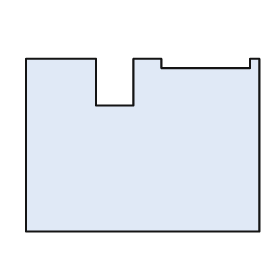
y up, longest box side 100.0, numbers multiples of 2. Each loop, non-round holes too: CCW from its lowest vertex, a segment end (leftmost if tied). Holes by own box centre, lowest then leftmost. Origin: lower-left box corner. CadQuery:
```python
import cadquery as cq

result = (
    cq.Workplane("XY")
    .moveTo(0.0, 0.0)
    .lineTo(100.0, 0.0)
    .lineTo(100.0, 74.0)
    .lineTo(96.0, 74.0)
    .lineTo(96.0, 70.0)
    .lineTo(58.0, 70.0)
    .lineTo(58.0, 74.0)
    .lineTo(46.0, 74.0)
    .lineTo(46.0, 54.0)
    .lineTo(30.0, 54.0)
    .lineTo(30.0, 74.0)
    .lineTo(0.0, 74.0)
    .close()
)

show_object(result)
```